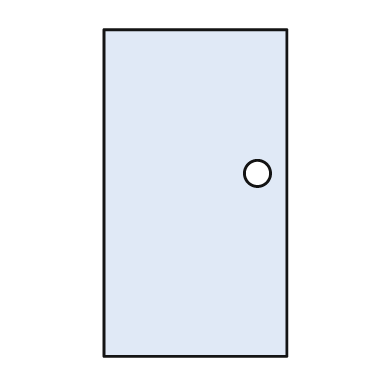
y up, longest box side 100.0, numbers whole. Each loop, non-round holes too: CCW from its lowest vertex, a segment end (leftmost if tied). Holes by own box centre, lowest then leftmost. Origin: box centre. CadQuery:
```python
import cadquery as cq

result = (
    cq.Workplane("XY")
    .moveTo(-28.0, -50.0)
    .lineTo(28.0, -50.0)
    .lineTo(28.0, 50.0)
    .lineTo(-28.0, 50.0)
    .close()
    .moveTo(19.0, 6.0)
    .circle(4.0)
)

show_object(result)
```